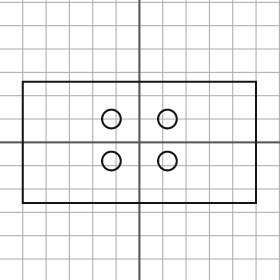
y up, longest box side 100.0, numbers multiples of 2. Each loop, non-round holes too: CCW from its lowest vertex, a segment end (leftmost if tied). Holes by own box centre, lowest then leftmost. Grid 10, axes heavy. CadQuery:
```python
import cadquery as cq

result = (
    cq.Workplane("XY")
    .moveTo(-50.0, -26.0)
    .lineTo(50.0, -26.0)
    .lineTo(50.0, 26.0)
    .lineTo(-50.0, 26.0)
    .close()
    .moveTo(-12.0, -8.0)
    .circle(4.0)
    .moveTo(12.0, -8.0)
    .circle(4.0)
    .moveTo(-12.0, 10.0)
    .circle(4.0)
    .moveTo(12.0, 10.0)
    .circle(4.0)
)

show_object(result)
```